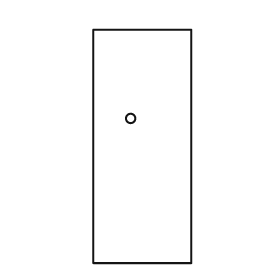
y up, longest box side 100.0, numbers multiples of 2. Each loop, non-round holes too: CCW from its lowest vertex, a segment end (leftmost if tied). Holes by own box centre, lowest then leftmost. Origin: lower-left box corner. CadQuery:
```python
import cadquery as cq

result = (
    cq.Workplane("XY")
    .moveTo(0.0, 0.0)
    .lineTo(42.0, 0.0)
    .lineTo(42.0, 100.0)
    .lineTo(0.0, 100.0)
    .close()
    .moveTo(16.0, 62.0)
    .circle(2.0)
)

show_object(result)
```